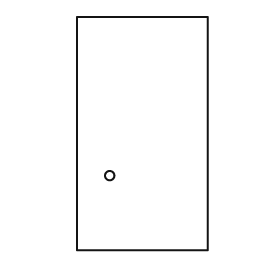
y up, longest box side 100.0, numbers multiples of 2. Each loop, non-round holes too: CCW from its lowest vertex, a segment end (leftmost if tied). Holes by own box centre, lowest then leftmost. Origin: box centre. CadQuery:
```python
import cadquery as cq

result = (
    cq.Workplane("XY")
    .moveTo(-28.0, -50.0)
    .lineTo(28.0, -50.0)
    .lineTo(28.0, 50.0)
    .lineTo(-28.0, 50.0)
    .close()
    .moveTo(-14.0, -18.0)
    .circle(2.0)
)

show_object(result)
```